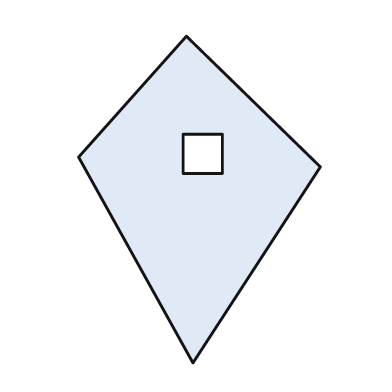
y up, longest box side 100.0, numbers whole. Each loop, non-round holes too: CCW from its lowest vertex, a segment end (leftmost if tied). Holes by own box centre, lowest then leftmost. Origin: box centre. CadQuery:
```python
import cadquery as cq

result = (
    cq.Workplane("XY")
    .moveTo(-2.0, -50.0)
    .lineTo(37.0, 10.0)
    .lineTo(-4.0, 50.0)
    .lineTo(-37.0, 13.0)
    .close()
    .moveTo(-5.0, 8.0)
    .lineTo(7.0, 8.0)
    .lineTo(7.0, 20.0)
    .lineTo(-5.0, 20.0)
    .close()
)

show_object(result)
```